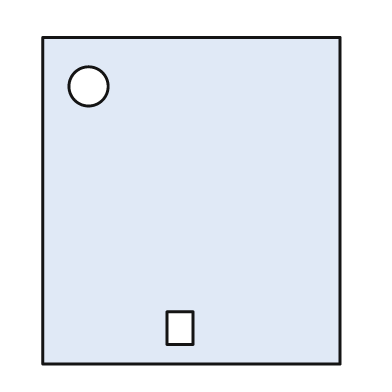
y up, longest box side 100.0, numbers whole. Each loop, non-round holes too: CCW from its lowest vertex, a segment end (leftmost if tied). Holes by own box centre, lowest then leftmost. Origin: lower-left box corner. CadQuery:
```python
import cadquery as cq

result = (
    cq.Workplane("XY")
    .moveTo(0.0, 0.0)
    .lineTo(91.0, 0.0)
    .lineTo(91.0, 100.0)
    .lineTo(0.0, 100.0)
    .close()
    .moveTo(38.0, 6.0)
    .lineTo(46.0, 6.0)
    .lineTo(46.0, 16.0)
    .lineTo(38.0, 16.0)
    .close()
    .moveTo(14.0, 85.0)
    .circle(6.0)
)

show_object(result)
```